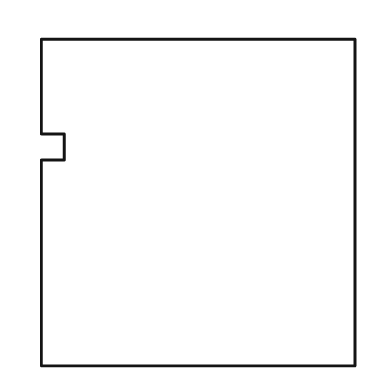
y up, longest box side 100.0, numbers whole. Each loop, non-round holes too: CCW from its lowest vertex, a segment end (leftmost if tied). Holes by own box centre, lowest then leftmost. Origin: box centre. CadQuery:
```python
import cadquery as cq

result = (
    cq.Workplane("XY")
    .moveTo(-48.0, -50.0)
    .lineTo(48.0, -50.0)
    .lineTo(48.0, 50.0)
    .lineTo(-48.0, 50.0)
    .lineTo(-48.0, 21.0)
    .lineTo(-41.0, 21.0)
    .lineTo(-41.0, 13.0)
    .lineTo(-48.0, 13.0)
    .close()
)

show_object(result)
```